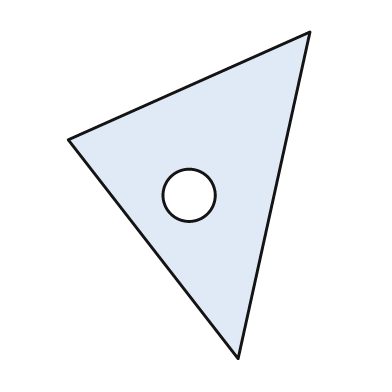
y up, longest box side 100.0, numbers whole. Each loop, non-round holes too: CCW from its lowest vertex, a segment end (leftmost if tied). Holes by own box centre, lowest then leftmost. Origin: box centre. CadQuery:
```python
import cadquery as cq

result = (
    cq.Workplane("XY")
    .moveTo(15.0, -50.0)
    .lineTo(37.0, 50.0)
    .lineTo(-37.0, 17.0)
    .close()
    .moveTo(0.0, 0.0)
    .circle(8.0)
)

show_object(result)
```